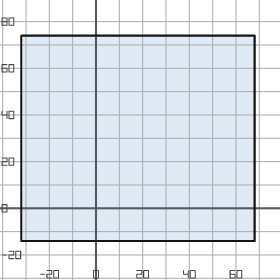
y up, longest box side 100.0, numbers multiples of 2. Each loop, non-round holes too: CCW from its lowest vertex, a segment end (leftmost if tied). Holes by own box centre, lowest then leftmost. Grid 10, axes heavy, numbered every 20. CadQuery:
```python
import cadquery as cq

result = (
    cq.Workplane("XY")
    .moveTo(-32.0, -14.0)
    .lineTo(68.0, -14.0)
    .lineTo(68.0, 74.0)
    .lineTo(-32.0, 74.0)
    .close()
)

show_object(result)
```